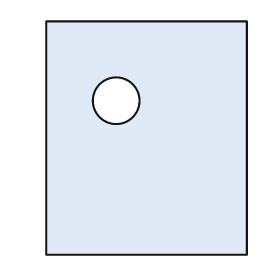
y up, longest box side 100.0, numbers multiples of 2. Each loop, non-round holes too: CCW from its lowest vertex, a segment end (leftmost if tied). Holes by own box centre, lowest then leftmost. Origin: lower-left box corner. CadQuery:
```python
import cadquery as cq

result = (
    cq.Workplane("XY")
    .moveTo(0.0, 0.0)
    .lineTo(86.0, 0.0)
    .lineTo(86.0, 100.0)
    .lineTo(0.0, 100.0)
    .close()
    .moveTo(30.0, 66.0)
    .circle(10.0)
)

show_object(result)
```